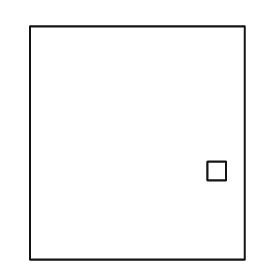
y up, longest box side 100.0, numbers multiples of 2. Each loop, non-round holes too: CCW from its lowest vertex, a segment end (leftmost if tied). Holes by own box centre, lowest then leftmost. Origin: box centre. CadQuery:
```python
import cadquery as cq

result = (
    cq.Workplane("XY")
    .moveTo(-46.0, -50.0)
    .lineTo(46.0, -50.0)
    .lineTo(46.0, 50.0)
    .lineTo(-46.0, 50.0)
    .close()
    .moveTo(30.0, -16.0)
    .lineTo(38.0, -16.0)
    .lineTo(38.0, -8.0)
    .lineTo(30.0, -8.0)
    .close()
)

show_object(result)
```